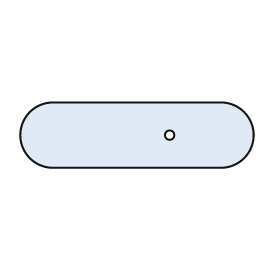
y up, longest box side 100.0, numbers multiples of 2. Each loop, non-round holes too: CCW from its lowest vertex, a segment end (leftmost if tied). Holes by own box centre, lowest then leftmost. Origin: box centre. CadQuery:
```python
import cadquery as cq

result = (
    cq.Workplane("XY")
    .moveTo(-36.0, -14.0)
    .lineTo(36.0, -14.0)
    .threePointArc((50.0, 0.0), (36.0, 14.0))
    .lineTo(-36.0, 14.0)
    .threePointArc((-50.0, 0.0), (-36.0, -14.0))
    .close()
    .moveTo(14.0, 0.0)
    .circle(2.0)
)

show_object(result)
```